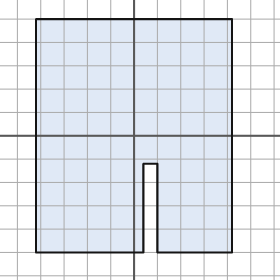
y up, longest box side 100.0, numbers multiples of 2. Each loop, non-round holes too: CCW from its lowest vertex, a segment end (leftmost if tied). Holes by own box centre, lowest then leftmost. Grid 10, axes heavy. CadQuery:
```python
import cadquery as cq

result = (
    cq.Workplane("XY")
    .moveTo(-42.0, -50.0)
    .lineTo(4.0, -50.0)
    .lineTo(4.0, -12.0)
    .lineTo(10.0, -12.0)
    .lineTo(10.0, -50.0)
    .lineTo(42.0, -50.0)
    .lineTo(42.0, 50.0)
    .lineTo(-42.0, 50.0)
    .close()
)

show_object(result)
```